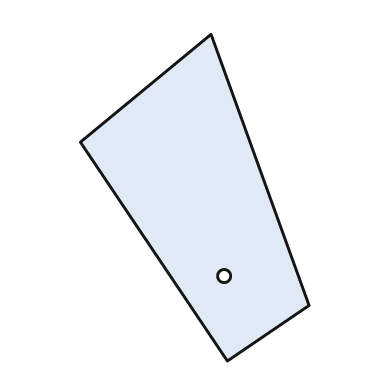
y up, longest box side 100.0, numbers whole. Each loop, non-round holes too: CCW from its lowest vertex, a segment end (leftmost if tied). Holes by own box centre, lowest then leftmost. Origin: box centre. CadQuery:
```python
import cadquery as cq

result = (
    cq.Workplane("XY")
    .moveTo(10.0, -50.0)
    .lineTo(35.0, -33.0)
    .lineTo(5.0, 50.0)
    .lineTo(-35.0, 17.0)
    .close()
    .moveTo(9.0, -24.0)
    .circle(2.0)
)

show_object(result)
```